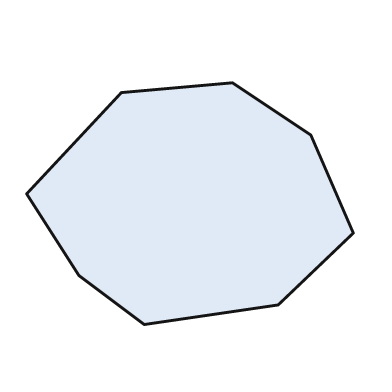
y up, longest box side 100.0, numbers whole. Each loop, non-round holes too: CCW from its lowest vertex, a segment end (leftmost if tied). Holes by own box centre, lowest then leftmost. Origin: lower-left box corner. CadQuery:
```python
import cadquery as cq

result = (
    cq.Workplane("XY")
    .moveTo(36.0, 0.0)
    .lineTo(77.0, 6.0)
    .lineTo(100.0, 28.0)
    .lineTo(87.0, 58.0)
    .lineTo(63.0, 74.0)
    .lineTo(29.0, 71.0)
    .lineTo(0.0, 40.0)
    .lineTo(16.0, 15.0)
    .close()
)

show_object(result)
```